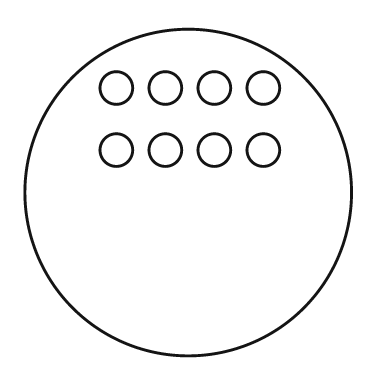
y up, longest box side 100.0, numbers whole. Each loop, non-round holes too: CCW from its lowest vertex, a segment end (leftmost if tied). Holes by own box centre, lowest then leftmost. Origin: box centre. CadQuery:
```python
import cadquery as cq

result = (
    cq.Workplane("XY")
    .moveTo(0.0, 0.0)
    .circle(50.0)
    .moveTo(-22.0, 13.0)
    .circle(5.0)
    .moveTo(-7.0, 13.0)
    .circle(5.0)
    .moveTo(8.0, 13.0)
    .circle(5.0)
    .moveTo(23.0, 13.0)
    .circle(5.0)
    .moveTo(-22.0, 32.0)
    .circle(5.0)
    .moveTo(-7.0, 32.0)
    .circle(5.0)
    .moveTo(8.0, 32.0)
    .circle(5.0)
    .moveTo(23.0, 32.0)
    .circle(5.0)
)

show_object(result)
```